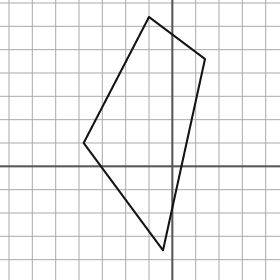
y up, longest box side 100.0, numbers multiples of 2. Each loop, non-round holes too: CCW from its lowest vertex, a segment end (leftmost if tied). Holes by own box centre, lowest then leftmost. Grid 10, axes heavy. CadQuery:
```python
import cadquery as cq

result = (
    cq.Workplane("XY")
    .moveTo(-4.0, -36.0)
    .lineTo(14.0, 46.0)
    .lineTo(-10.0, 64.0)
    .lineTo(-38.0, 10.0)
    .close()
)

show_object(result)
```